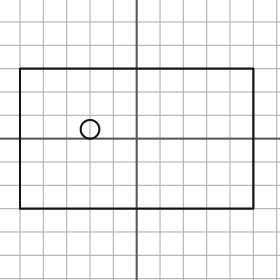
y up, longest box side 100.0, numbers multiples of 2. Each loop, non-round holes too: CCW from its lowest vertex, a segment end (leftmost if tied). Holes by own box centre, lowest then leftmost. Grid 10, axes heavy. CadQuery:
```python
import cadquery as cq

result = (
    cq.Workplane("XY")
    .moveTo(-50.0, -30.0)
    .lineTo(50.0, -30.0)
    .lineTo(50.0, 30.0)
    .lineTo(-50.0, 30.0)
    .close()
    .moveTo(-20.0, 4.0)
    .circle(4.0)
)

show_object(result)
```